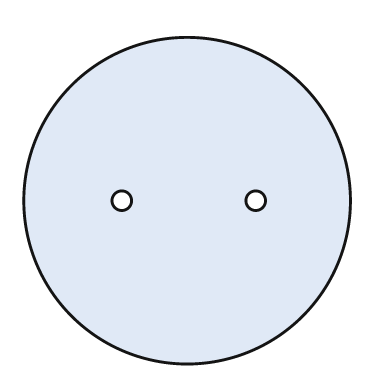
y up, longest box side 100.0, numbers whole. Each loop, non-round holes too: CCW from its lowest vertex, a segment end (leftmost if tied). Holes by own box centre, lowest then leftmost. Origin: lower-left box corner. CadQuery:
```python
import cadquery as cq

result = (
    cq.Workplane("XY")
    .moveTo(50.0, 50.0)
    .circle(50.0)
    .moveTo(30.0, 50.0)
    .circle(3.0)
    .moveTo(71.0, 50.0)
    .circle(3.0)
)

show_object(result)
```